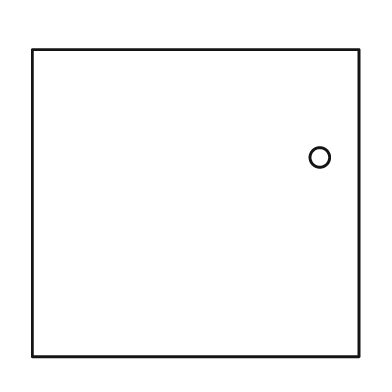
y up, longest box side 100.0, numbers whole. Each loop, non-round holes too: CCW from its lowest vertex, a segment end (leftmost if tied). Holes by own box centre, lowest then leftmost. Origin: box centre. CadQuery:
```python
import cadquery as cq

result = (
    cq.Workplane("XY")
    .moveTo(-50.0, -47.0)
    .lineTo(50.0, -47.0)
    .lineTo(50.0, 47.0)
    .lineTo(-50.0, 47.0)
    .close()
    .moveTo(38.0, 14.0)
    .circle(3.0)
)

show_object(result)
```